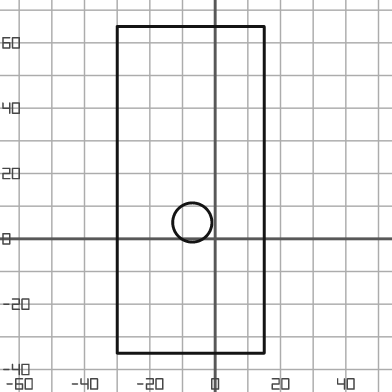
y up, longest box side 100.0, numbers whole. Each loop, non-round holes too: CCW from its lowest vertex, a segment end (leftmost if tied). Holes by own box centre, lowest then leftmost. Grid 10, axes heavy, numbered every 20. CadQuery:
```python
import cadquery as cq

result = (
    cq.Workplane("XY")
    .moveTo(-30.0, -35.0)
    .lineTo(15.0, -35.0)
    .lineTo(15.0, 65.0)
    .lineTo(-30.0, 65.0)
    .close()
    .moveTo(-7.0, 5.0)
    .circle(6.0)
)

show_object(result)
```